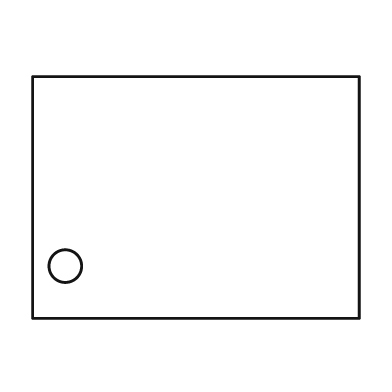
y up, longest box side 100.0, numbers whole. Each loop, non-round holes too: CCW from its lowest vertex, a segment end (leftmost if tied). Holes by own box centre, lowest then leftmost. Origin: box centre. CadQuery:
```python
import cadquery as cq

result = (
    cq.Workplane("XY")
    .moveTo(-50.0, -37.0)
    .lineTo(50.0, -37.0)
    .lineTo(50.0, 37.0)
    .lineTo(-50.0, 37.0)
    .close()
    .moveTo(-40.0, -21.0)
    .circle(5.0)
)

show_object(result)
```